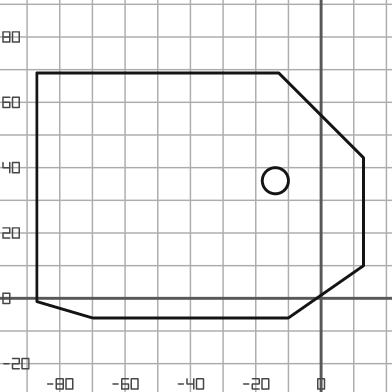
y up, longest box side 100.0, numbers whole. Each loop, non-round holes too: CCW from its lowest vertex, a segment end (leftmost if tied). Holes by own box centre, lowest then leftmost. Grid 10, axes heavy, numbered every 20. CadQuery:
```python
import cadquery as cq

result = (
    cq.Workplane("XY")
    .moveTo(-70.0, -6.0)
    .lineTo(-10.0, -6.0)
    .lineTo(13.0, 10.0)
    .lineTo(13.0, 43.0)
    .lineTo(-13.0, 69.0)
    .lineTo(-87.0, 69.0)
    .lineTo(-87.0, -1.0)
    .close()
    .moveTo(-14.0, 36.0)
    .circle(4.0)
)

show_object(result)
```